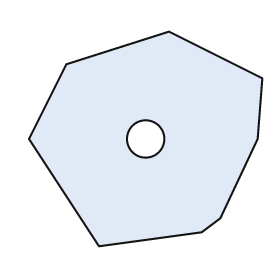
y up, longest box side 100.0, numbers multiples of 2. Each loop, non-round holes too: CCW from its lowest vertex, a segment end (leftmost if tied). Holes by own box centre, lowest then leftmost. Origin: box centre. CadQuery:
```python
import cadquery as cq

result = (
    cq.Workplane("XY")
    .moveTo(-20.0, -46.0)
    .lineTo(24.0, -40.0)
    .lineTo(32.0, -34.0)
    .lineTo(48.0, 0.0)
    .lineTo(50.0, 26.0)
    .lineTo(10.0, 46.0)
    .lineTo(-34.0, 32.0)
    .lineTo(-50.0, 0.0)
    .close()
    .moveTo(0.0, 0.0)
    .circle(8.0)
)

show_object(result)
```